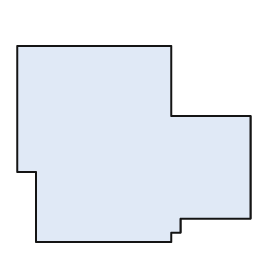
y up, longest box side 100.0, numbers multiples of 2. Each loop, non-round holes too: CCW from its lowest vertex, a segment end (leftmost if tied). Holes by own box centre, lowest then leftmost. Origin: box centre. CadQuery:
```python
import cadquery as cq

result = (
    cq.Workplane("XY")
    .moveTo(-42.0, -42.0)
    .lineTo(16.0, -42.0)
    .lineTo(16.0, -38.0)
    .lineTo(20.0, -38.0)
    .lineTo(20.0, -32.0)
    .lineTo(50.0, -32.0)
    .lineTo(50.0, 12.0)
    .lineTo(16.0, 12.0)
    .lineTo(16.0, 42.0)
    .lineTo(-50.0, 42.0)
    .lineTo(-50.0, -12.0)
    .lineTo(-42.0, -12.0)
    .close()
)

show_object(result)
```